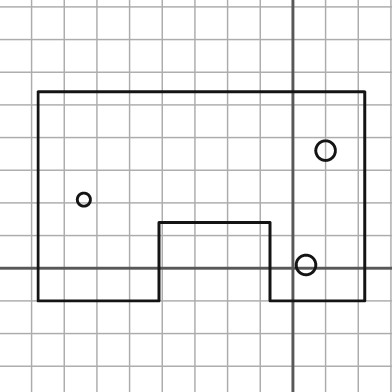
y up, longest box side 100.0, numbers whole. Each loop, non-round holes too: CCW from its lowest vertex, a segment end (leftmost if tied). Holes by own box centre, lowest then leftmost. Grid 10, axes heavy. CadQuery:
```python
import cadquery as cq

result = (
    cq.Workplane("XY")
    .moveTo(-78.0, -10.0)
    .lineTo(-41.0, -10.0)
    .lineTo(-41.0, 14.0)
    .lineTo(-7.0, 14.0)
    .lineTo(-7.0, -10.0)
    .lineTo(22.0, -10.0)
    .lineTo(22.0, 54.0)
    .lineTo(-78.0, 54.0)
    .close()
    .moveTo(4.0, 1.0)
    .circle(3.0)
    .moveTo(-64.0, 21.0)
    .circle(2.0)
    .moveTo(10.0, 36.0)
    .circle(3.0)
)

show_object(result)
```